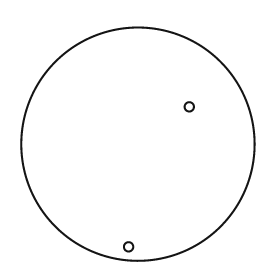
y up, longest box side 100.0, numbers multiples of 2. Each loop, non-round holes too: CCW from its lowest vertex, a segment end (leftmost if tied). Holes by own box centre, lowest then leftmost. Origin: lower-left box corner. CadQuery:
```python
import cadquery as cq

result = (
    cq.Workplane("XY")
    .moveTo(50.0, 50.0)
    .circle(50.0)
    .moveTo(46.0, 6.0)
    .circle(2.0)
    .moveTo(72.0, 66.0)
    .circle(2.0)
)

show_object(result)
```